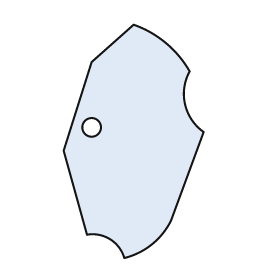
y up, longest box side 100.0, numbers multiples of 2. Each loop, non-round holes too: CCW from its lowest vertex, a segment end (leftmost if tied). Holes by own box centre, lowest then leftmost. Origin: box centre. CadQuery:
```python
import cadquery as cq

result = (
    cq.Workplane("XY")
    .moveTo(-4.0, -50.0)
    .threePointArc((8.0, -44.0), (16.0, -34.0))
    .lineTo(30.0, 4.0)
    .threePointArc((22.0, 16.0), (24.0, 30.0))
    .threePointArc((14.0, 42.0), (0.0, 50.0))
    .lineTo(-18.0, 34.0)
    .lineTo(-30.0, -4.0)
    .lineTo(-20.0, -40.0)
    .threePointArc((-10.0, -42.0), (-4.0, -50.0))
    .close()
    .moveTo(-18.0, 6.0)
    .circle(4.0)
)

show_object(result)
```